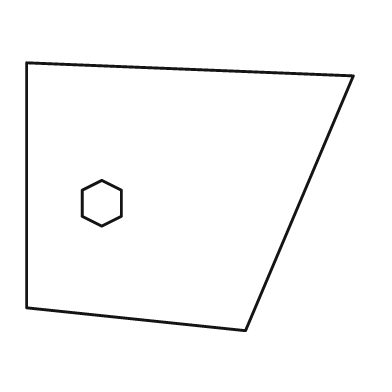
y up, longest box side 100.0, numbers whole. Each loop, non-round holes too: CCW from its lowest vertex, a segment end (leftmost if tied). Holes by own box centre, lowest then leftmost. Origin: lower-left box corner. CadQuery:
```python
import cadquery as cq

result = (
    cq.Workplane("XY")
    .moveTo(67.0, 0.0)
    .lineTo(100.0, 78.0)
    .lineTo(0.0, 82.0)
    .lineTo(0.0, 7.0)
    .close()
    .moveTo(23.0, 32.0)
    .lineTo(29.0, 35.0)
    .lineTo(29.0, 43.0)
    .lineTo(23.0, 46.0)
    .lineTo(17.0, 43.0)
    .lineTo(17.0, 35.0)
    .close()
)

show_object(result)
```